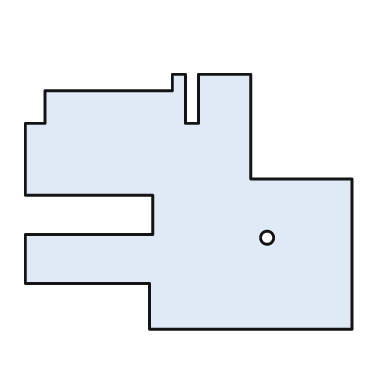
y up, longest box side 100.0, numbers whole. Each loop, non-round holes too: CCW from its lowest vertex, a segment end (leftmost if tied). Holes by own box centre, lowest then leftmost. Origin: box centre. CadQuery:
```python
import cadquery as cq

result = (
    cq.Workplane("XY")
    .moveTo(-12.0, -39.0)
    .lineTo(50.0, -39.0)
    .lineTo(50.0, 7.0)
    .lineTo(19.0, 7.0)
    .lineTo(19.0, 39.0)
    .lineTo(3.0, 39.0)
    .lineTo(3.0, 24.0)
    .lineTo(-1.0, 24.0)
    .lineTo(-1.0, 39.0)
    .lineTo(-5.0, 39.0)
    .lineTo(-5.0, 34.0)
    .lineTo(-44.0, 34.0)
    .lineTo(-44.0, 24.0)
    .lineTo(-50.0, 24.0)
    .lineTo(-50.0, 2.0)
    .lineTo(-11.0, 2.0)
    .lineTo(-11.0, -10.0)
    .lineTo(-50.0, -10.0)
    .lineTo(-50.0, -25.0)
    .lineTo(-12.0, -25.0)
    .close()
    .moveTo(24.0, -11.0)
    .circle(2.0)
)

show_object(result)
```